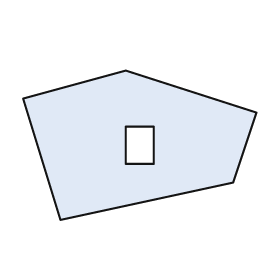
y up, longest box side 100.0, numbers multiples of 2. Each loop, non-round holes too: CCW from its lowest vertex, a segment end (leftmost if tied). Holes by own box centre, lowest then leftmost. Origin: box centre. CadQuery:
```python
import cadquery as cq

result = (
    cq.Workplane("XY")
    .moveTo(-34.0, -32.0)
    .lineTo(40.0, -16.0)
    .lineTo(50.0, 14.0)
    .lineTo(-6.0, 32.0)
    .lineTo(-50.0, 20.0)
    .close()
    .moveTo(-6.0, -8.0)
    .lineTo(6.0, -8.0)
    .lineTo(6.0, 8.0)
    .lineTo(-6.0, 8.0)
    .close()
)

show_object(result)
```